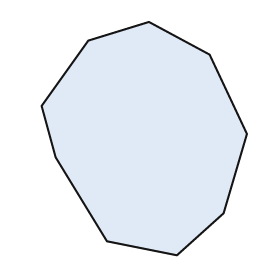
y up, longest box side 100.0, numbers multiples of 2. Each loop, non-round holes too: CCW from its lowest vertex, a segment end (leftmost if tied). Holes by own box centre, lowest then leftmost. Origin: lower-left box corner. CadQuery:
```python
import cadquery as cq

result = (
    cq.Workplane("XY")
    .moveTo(58.0, 0.0)
    .lineTo(78.0, 18.0)
    .lineTo(88.0, 52.0)
    .lineTo(72.0, 86.0)
    .lineTo(46.0, 100.0)
    .lineTo(20.0, 92.0)
    .lineTo(0.0, 64.0)
    .lineTo(6.0, 42.0)
    .lineTo(28.0, 6.0)
    .close()
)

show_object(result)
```